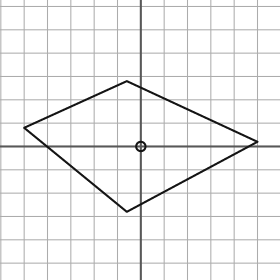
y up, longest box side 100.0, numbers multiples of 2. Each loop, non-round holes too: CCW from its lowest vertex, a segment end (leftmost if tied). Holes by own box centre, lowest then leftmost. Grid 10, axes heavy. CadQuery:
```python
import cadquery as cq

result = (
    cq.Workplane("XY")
    .moveTo(-6.0, -28.0)
    .lineTo(50.0, 2.0)
    .lineTo(-6.0, 28.0)
    .lineTo(-50.0, 8.0)
    .close()
    .moveTo(0.0, 0.0)
    .circle(2.0)
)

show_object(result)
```